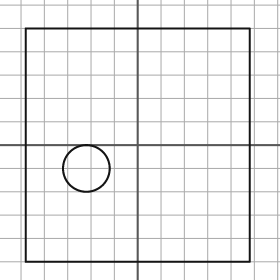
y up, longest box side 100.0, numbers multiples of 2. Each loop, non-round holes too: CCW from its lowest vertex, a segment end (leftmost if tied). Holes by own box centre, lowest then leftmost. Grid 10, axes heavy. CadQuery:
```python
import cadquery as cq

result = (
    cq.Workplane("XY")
    .moveTo(-48.0, -50.0)
    .lineTo(48.0, -50.0)
    .lineTo(48.0, 50.0)
    .lineTo(-48.0, 50.0)
    .close()
    .moveTo(-22.0, -10.0)
    .circle(10.0)
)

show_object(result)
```